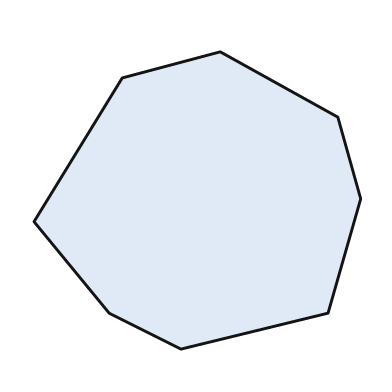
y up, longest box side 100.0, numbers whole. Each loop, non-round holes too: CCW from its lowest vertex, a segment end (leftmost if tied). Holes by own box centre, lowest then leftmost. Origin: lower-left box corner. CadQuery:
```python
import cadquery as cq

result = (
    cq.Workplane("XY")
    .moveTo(45.0, 0.0)
    .lineTo(90.0, 11.0)
    .lineTo(100.0, 46.0)
    .lineTo(93.0, 71.0)
    .lineTo(57.0, 91.0)
    .lineTo(27.0, 83.0)
    .lineTo(0.0, 39.0)
    .lineTo(23.0, 11.0)
    .close()
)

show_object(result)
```